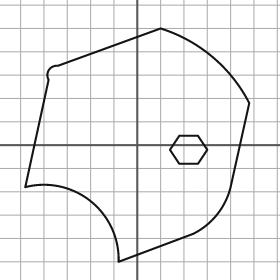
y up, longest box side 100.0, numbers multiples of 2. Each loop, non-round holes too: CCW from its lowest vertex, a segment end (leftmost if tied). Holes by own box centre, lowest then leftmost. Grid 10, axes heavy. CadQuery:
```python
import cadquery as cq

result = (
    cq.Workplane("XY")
    .moveTo(-8.0, -50.0)
    .lineTo(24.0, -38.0)
    .threePointArc((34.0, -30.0), (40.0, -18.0))
    .lineTo(48.0, 18.0)
    .threePointArc((32.0, 38.0), (10.0, 50.0))
    .lineTo(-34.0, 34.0)
    .threePointArc((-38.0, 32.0), (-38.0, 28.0))
    .lineTo(-48.0, -18.0)
    .threePointArc((-20.0, -24.0), (-8.0, -50.0))
    .close()
    .moveTo(18.0, -8.0)
    .lineTo(26.0, -8.0)
    .lineTo(30.0, -2.0)
    .lineTo(26.0, 4.0)
    .lineTo(18.0, 4.0)
    .lineTo(14.0, -2.0)
    .close()
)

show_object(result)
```